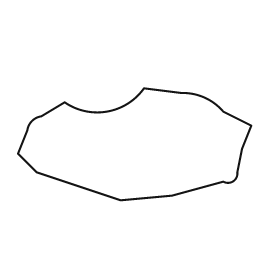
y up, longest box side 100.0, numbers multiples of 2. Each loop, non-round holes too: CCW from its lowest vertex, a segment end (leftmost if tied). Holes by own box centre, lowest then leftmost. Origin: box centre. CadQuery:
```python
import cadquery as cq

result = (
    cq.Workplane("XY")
    .moveTo(-6.0, -24.0)
    .lineTo(16.0, -22.0)
    .lineTo(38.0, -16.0)
    .threePointArc((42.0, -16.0), (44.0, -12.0))
    .lineTo(46.0, -2.0)
    .lineTo(50.0, 8.0)
    .lineTo(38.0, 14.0)
    .threePointArc((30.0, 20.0), (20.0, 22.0))
    .lineTo(4.0, 24.0)
    .threePointArc((-12.0, 14.0), (-30.0, 18.0))
    .lineTo(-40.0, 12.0)
    .threePointArc((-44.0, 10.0), (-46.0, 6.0))
    .lineTo(-50.0, -4.0)
    .lineTo(-42.0, -12.0)
    .close()
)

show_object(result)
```